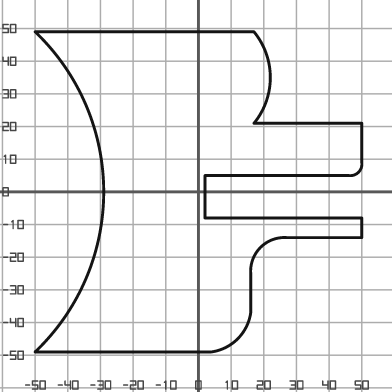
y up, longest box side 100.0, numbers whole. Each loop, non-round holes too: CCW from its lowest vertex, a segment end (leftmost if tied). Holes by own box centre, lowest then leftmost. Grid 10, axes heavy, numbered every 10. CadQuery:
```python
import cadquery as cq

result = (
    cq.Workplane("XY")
    .moveTo(-50.0, -49.0)
    .lineTo(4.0, -49.0)
    .threePointArc((12.0, -45.0), (16.0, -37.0))
    .lineTo(16.0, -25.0)
    .threePointArc((19.0, -17.0), (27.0, -14.0))
    .lineTo(50.0, -14.0)
    .lineTo(50.0, -8.0)
    .lineTo(2.0, -8.0)
    .lineTo(2.0, 5.0)
    .lineTo(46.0, 5.0)
    .threePointArc((49.0, 6.0), (50.0, 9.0))
    .lineTo(50.0, 21.0)
    .lineTo(17.0, 21.0)
    .threePointArc((22.0, 35.0), (17.0, 49.0))
    .lineTo(-50.0, 49.0)
    .threePointArc((-29.0, 0.0), (-50.0, -49.0))
    .close()
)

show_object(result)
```